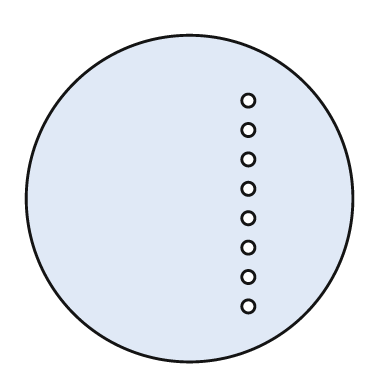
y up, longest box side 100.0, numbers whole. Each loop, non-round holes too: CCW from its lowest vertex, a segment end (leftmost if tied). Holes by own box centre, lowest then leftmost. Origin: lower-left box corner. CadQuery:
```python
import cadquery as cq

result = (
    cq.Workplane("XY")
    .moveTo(50.0, 50.0)
    .circle(50.0)
    .moveTo(68.0, 17.0)
    .circle(2.0)
    .moveTo(68.0, 26.0)
    .circle(2.0)
    .moveTo(68.0, 35.0)
    .circle(2.0)
    .moveTo(68.0, 44.0)
    .circle(2.0)
    .moveTo(68.0, 53.0)
    .circle(2.0)
    .moveTo(68.0, 62.0)
    .circle(2.0)
    .moveTo(68.0, 71.0)
    .circle(2.0)
    .moveTo(68.0, 80.0)
    .circle(2.0)
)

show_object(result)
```